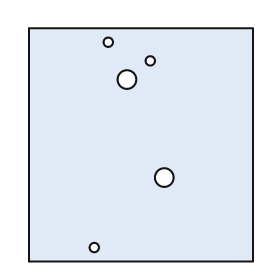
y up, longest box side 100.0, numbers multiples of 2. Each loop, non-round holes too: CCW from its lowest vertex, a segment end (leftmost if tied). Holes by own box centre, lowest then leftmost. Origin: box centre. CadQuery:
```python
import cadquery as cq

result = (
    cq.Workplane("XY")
    .moveTo(-48.0, -50.0)
    .lineTo(48.0, -50.0)
    .lineTo(48.0, 50.0)
    .lineTo(-48.0, 50.0)
    .close()
    .moveTo(-20.0, -44.0)
    .circle(2.0)
    .moveTo(10.0, -14.0)
    .circle(4.0)
    .moveTo(-6.0, 28.0)
    .circle(4.0)
    .moveTo(4.0, 36.0)
    .circle(2.0)
    .moveTo(-14.0, 44.0)
    .circle(2.0)
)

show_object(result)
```